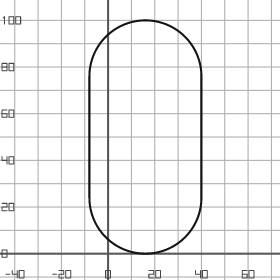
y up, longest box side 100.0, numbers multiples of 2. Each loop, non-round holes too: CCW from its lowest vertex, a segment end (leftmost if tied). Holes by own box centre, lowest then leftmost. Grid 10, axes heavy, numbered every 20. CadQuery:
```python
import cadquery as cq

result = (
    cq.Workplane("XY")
    .moveTo(-8.0, 24.0)
    .threePointArc((16.0, 0.0), (40.0, 24.0))
    .lineTo(40.0, 76.0)
    .threePointArc((16.0, 100.0), (-8.0, 76.0))
    .close()
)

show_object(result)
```